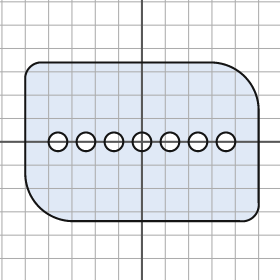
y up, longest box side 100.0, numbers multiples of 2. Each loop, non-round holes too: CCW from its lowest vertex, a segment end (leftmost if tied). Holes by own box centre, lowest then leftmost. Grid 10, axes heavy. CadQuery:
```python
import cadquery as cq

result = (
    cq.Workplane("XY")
    .moveTo(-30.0, -34.0)
    .lineTo(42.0, -34.0)
    .threePointArc((48.0, -32.0), (50.0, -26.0))
    .lineTo(50.0, 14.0)
    .threePointArc((44.0, 28.0), (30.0, 34.0))
    .lineTo(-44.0, 34.0)
    .threePointArc((-48.0, 32.0), (-50.0, 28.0))
    .lineTo(-50.0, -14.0)
    .threePointArc((-44.0, -28.0), (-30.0, -34.0))
    .close()
    .moveTo(-36.0, 0.0)
    .circle(4.0)
    .moveTo(-24.0, 0.0)
    .circle(4.0)
    .moveTo(-12.0, 0.0)
    .circle(4.0)
    .moveTo(0.0, 0.0)
    .circle(4.0)
    .moveTo(12.0, 0.0)
    .circle(4.0)
    .moveTo(24.0, 0.0)
    .circle(4.0)
    .moveTo(36.0, 0.0)
    .circle(4.0)
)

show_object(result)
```